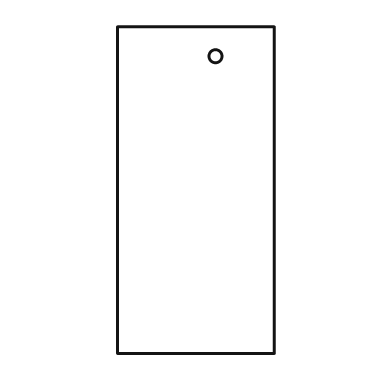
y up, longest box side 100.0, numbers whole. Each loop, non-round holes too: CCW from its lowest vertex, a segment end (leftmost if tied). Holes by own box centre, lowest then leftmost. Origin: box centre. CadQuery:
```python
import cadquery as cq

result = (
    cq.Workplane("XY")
    .moveTo(-24.0, -50.0)
    .lineTo(24.0, -50.0)
    .lineTo(24.0, 50.0)
    .lineTo(-24.0, 50.0)
    .close()
    .moveTo(6.0, 41.0)
    .circle(2.0)
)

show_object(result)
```